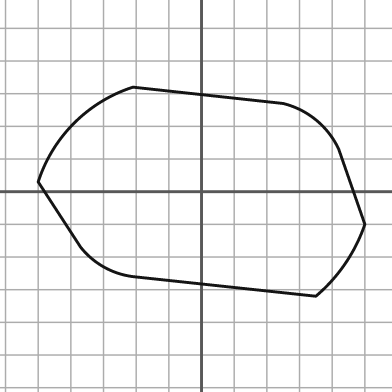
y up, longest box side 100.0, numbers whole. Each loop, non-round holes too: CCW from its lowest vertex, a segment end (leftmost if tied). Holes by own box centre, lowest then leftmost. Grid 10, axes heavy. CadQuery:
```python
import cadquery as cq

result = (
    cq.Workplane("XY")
    .moveTo(35.0, -32.0)
    .threePointArc((44.0, -22.0), (50.0, -10.0))
    .lineTo(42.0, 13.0)
    .threePointArc((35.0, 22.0), (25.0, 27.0))
    .lineTo(-21.0, 32.0)
    .threePointArc((-39.0, 21.0), (-50.0, 3.0))
    .lineTo(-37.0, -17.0)
    .threePointArc((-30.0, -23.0), (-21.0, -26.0))
    .close()
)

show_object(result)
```